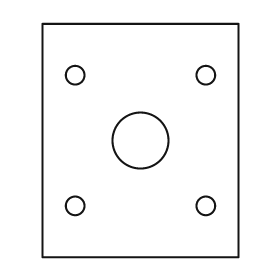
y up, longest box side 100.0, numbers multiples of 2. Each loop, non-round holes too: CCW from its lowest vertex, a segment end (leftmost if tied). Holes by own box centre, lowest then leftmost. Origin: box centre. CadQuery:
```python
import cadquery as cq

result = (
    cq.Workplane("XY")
    .moveTo(-42.0, -50.0)
    .lineTo(42.0, -50.0)
    .lineTo(42.0, 50.0)
    .lineTo(-42.0, 50.0)
    .close()
    .moveTo(-28.0, -28.0)
    .circle(4.0)
    .moveTo(28.0, -28.0)
    .circle(4.0)
    .moveTo(0.0, 0.0)
    .circle(12.0)
    .moveTo(-28.0, 28.0)
    .circle(4.0)
    .moveTo(28.0, 28.0)
    .circle(4.0)
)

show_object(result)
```